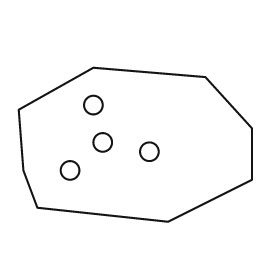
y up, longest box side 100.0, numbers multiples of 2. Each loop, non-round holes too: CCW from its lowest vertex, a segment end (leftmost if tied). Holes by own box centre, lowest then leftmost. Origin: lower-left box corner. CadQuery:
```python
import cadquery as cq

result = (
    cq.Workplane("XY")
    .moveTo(64.0, 0.0)
    .lineTo(100.0, 18.0)
    .lineTo(100.0, 40.0)
    .lineTo(80.0, 62.0)
    .lineTo(32.0, 66.0)
    .lineTo(0.0, 48.0)
    .lineTo(2.0, 22.0)
    .lineTo(8.0, 6.0)
    .close()
    .moveTo(22.0, 22.0)
    .circle(4.0)
    .moveTo(56.0, 30.0)
    .circle(4.0)
    .moveTo(36.0, 34.0)
    .circle(4.0)
    .moveTo(32.0, 50.0)
    .circle(4.0)
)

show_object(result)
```